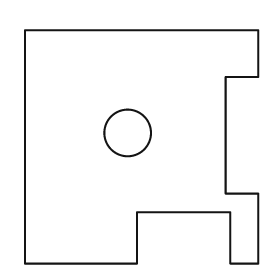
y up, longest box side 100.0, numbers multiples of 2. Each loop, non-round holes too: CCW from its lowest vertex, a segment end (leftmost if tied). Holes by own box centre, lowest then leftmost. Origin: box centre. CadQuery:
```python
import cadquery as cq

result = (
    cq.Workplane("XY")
    .moveTo(-50.0, -50.0)
    .lineTo(-2.0, -50.0)
    .lineTo(-2.0, -28.0)
    .lineTo(38.0, -28.0)
    .lineTo(38.0, -50.0)
    .lineTo(50.0, -50.0)
    .lineTo(50.0, -20.0)
    .lineTo(36.0, -20.0)
    .lineTo(36.0, 30.0)
    .lineTo(50.0, 30.0)
    .lineTo(50.0, 50.0)
    .lineTo(-50.0, 50.0)
    .close()
    .moveTo(-6.0, 6.0)
    .circle(10.0)
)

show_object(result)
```